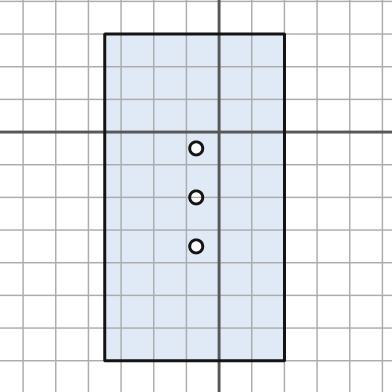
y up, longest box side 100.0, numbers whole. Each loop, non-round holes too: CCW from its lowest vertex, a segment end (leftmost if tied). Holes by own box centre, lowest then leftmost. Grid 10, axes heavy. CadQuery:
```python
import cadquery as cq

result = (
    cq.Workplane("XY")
    .moveTo(-35.0, -70.0)
    .lineTo(20.0, -70.0)
    .lineTo(20.0, 30.0)
    .lineTo(-35.0, 30.0)
    .close()
    .moveTo(-7.0, -35.0)
    .circle(2.0)
    .moveTo(-7.0, -20.0)
    .circle(2.0)
    .moveTo(-7.0, -5.0)
    .circle(2.0)
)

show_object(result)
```